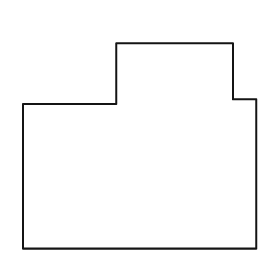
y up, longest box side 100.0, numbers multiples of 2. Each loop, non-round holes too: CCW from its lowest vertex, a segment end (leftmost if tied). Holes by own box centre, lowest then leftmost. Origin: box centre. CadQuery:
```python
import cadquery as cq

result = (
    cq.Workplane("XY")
    .moveTo(-50.0, -44.0)
    .lineTo(50.0, -44.0)
    .lineTo(50.0, 20.0)
    .lineTo(40.0, 20.0)
    .lineTo(40.0, 44.0)
    .lineTo(-10.0, 44.0)
    .lineTo(-10.0, 18.0)
    .lineTo(-50.0, 18.0)
    .close()
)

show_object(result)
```